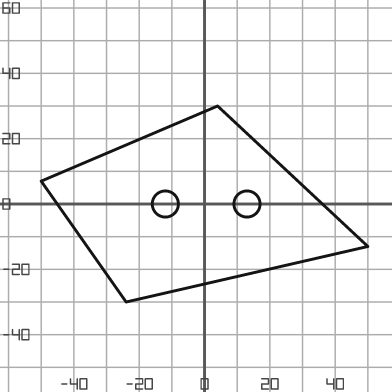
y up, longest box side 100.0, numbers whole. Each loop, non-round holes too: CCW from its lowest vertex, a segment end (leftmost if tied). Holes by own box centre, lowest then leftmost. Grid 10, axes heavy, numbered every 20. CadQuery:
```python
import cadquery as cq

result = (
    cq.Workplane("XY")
    .moveTo(-24.0, -30.0)
    .lineTo(50.0, -13.0)
    .lineTo(4.0, 30.0)
    .lineTo(-50.0, 7.0)
    .close()
    .moveTo(-12.0, 0.0)
    .circle(4.0)
    .moveTo(13.0, 0.0)
    .circle(4.0)
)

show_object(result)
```